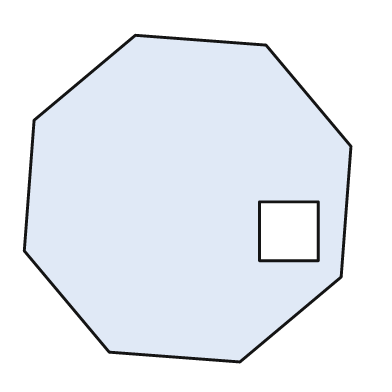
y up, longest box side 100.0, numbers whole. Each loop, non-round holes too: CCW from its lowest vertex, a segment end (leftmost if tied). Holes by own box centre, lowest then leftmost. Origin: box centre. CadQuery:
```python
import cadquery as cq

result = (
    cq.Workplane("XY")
    .moveTo(16.0, -50.0)
    .lineTo(47.0, -24.0)
    .lineTo(50.0, 16.0)
    .lineTo(24.0, 47.0)
    .lineTo(-16.0, 50.0)
    .lineTo(-47.0, 24.0)
    .lineTo(-50.0, -16.0)
    .lineTo(-24.0, -47.0)
    .close()
    .moveTo(22.0, -19.0)
    .lineTo(40.0, -19.0)
    .lineTo(40.0, -1.0)
    .lineTo(22.0, -1.0)
    .close()
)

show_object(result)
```